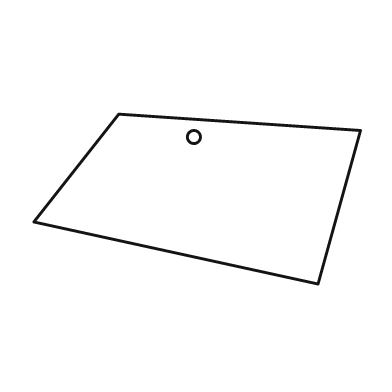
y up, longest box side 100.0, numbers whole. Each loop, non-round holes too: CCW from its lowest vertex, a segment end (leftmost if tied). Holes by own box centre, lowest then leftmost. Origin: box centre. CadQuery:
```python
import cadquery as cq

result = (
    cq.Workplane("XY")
    .moveTo(37.0, -26.0)
    .lineTo(50.0, 21.0)
    .lineTo(-24.0, 26.0)
    .lineTo(-50.0, -7.0)
    .close()
    .moveTo(-1.0, 19.0)
    .circle(2.0)
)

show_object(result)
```